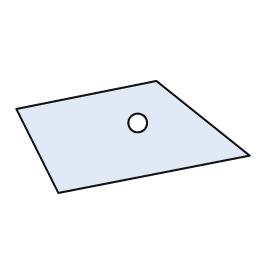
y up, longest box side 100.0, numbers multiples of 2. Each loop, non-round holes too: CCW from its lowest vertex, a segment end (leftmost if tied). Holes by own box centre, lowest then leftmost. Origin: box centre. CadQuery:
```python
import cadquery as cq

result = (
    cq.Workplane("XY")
    .moveTo(-32.0, -24.0)
    .lineTo(50.0, -8.0)
    .lineTo(10.0, 24.0)
    .lineTo(-50.0, 12.0)
    .close()
    .moveTo(2.0, 6.0)
    .circle(4.0)
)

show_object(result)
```